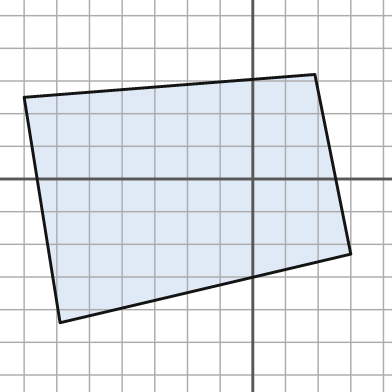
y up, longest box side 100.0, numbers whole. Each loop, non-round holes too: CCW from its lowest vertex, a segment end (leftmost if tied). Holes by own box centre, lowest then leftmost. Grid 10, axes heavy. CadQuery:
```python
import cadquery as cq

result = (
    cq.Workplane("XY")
    .moveTo(-59.0, -44.0)
    .lineTo(30.0, -23.0)
    .lineTo(19.0, 32.0)
    .lineTo(-70.0, 25.0)
    .close()
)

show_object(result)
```